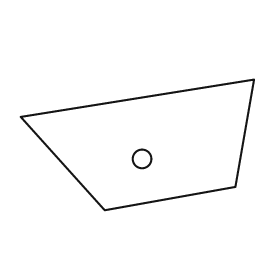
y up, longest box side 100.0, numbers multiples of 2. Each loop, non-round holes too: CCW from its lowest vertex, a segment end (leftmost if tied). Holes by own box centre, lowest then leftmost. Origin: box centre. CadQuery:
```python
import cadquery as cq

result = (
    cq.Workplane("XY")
    .moveTo(-14.0, -28.0)
    .lineTo(42.0, -18.0)
    .lineTo(50.0, 28.0)
    .lineTo(-50.0, 12.0)
    .close()
    .moveTo(2.0, -6.0)
    .circle(4.0)
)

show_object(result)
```